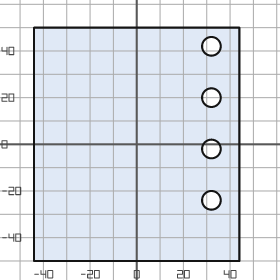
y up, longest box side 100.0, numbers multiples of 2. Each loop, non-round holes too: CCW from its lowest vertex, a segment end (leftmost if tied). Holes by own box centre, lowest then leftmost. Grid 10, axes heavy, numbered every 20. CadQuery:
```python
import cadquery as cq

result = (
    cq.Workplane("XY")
    .moveTo(-44.0, -50.0)
    .lineTo(44.0, -50.0)
    .lineTo(44.0, 50.0)
    .lineTo(-44.0, 50.0)
    .close()
    .moveTo(32.0, -24.0)
    .circle(4.0)
    .moveTo(32.0, -2.0)
    .circle(4.0)
    .moveTo(32.0, 20.0)
    .circle(4.0)
    .moveTo(32.0, 42.0)
    .circle(4.0)
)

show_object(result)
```